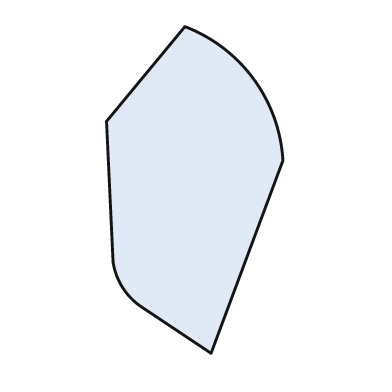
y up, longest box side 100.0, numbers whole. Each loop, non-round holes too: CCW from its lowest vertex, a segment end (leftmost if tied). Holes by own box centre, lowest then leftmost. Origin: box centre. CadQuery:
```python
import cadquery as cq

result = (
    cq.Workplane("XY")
    .moveTo(5.0, -50.0)
    .lineTo(27.0, 9.0)
    .threePointArc((18.0, 34.0), (-3.0, 50.0))
    .lineTo(-27.0, 21.0)
    .lineTo(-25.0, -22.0)
    .threePointArc((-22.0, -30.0), (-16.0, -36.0))
    .close()
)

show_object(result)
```